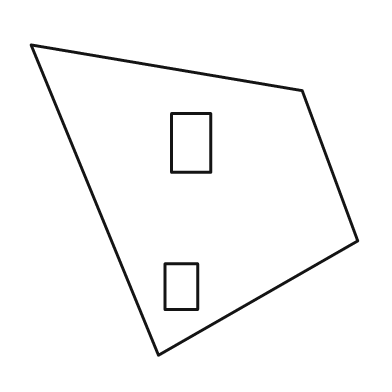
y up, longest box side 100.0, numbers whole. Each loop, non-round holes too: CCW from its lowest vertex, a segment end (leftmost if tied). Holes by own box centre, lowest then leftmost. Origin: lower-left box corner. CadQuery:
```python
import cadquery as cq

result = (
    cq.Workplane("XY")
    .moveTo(39.0, 0.0)
    .lineTo(100.0, 35.0)
    .lineTo(83.0, 81.0)
    .lineTo(0.0, 95.0)
    .close()
    .moveTo(41.0, 14.0)
    .lineTo(51.0, 14.0)
    .lineTo(51.0, 28.0)
    .lineTo(41.0, 28.0)
    .close()
    .moveTo(43.0, 56.0)
    .lineTo(55.0, 56.0)
    .lineTo(55.0, 74.0)
    .lineTo(43.0, 74.0)
    .close()
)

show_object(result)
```